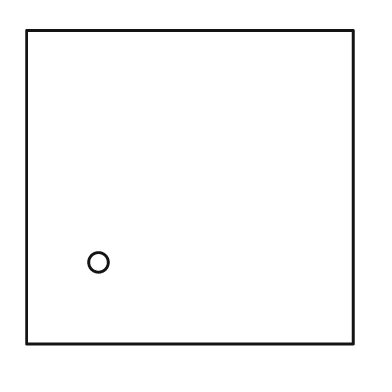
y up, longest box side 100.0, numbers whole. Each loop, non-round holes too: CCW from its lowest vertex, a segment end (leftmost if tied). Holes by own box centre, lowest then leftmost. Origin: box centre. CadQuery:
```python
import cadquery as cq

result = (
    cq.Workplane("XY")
    .moveTo(-50.0, -48.0)
    .lineTo(50.0, -48.0)
    .lineTo(50.0, 48.0)
    .lineTo(-50.0, 48.0)
    .close()
    .moveTo(-28.0, -23.0)
    .circle(3.0)
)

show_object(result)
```